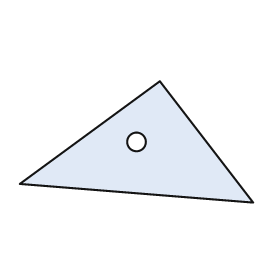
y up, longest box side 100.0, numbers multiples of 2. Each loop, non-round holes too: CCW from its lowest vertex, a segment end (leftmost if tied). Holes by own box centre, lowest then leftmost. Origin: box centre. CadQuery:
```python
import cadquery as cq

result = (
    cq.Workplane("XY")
    .moveTo(50.0, -26.0)
    .lineTo(10.0, 26.0)
    .lineTo(-50.0, -18.0)
    .close()
    .moveTo(0.0, 0.0)
    .circle(4.0)
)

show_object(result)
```